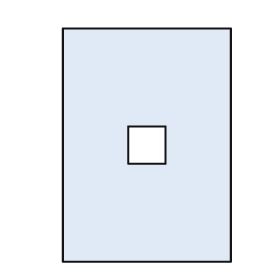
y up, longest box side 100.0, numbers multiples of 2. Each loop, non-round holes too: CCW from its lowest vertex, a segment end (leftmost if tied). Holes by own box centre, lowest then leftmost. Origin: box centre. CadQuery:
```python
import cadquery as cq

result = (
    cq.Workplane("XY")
    .moveTo(-36.0, -50.0)
    .lineTo(36.0, -50.0)
    .lineTo(36.0, 50.0)
    .lineTo(-36.0, 50.0)
    .close()
    .moveTo(-8.0, -8.0)
    .lineTo(8.0, -8.0)
    .lineTo(8.0, 8.0)
    .lineTo(-8.0, 8.0)
    .close()
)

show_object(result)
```